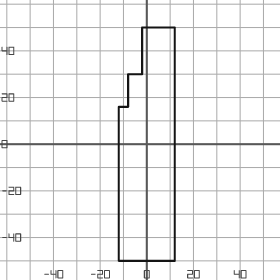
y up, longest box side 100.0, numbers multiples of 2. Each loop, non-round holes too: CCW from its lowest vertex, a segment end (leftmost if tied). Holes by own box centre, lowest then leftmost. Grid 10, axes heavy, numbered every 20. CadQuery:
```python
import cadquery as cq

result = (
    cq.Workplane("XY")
    .moveTo(-12.0, -50.0)
    .lineTo(12.0, -50.0)
    .lineTo(12.0, 50.0)
    .lineTo(-2.0, 50.0)
    .lineTo(-2.0, 30.0)
    .lineTo(-8.0, 30.0)
    .lineTo(-8.0, 16.0)
    .lineTo(-12.0, 16.0)
    .close()
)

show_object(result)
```